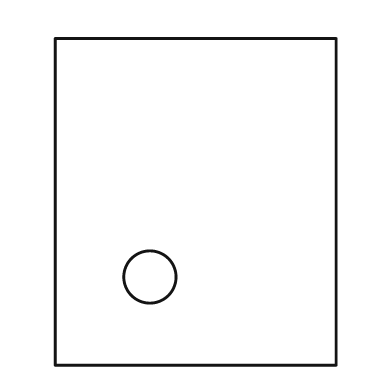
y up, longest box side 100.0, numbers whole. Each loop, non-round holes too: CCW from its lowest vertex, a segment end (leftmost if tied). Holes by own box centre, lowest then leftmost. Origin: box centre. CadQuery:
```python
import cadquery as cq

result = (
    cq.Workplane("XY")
    .moveTo(-43.0, -50.0)
    .lineTo(43.0, -50.0)
    .lineTo(43.0, 50.0)
    .lineTo(-43.0, 50.0)
    .close()
    .moveTo(-14.0, -23.0)
    .circle(8.0)
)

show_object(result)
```